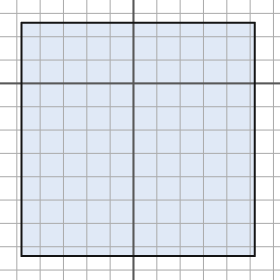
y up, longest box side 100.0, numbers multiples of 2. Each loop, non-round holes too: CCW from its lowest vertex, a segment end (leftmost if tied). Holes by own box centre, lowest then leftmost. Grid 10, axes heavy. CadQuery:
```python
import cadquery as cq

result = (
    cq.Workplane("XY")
    .moveTo(-48.0, -74.0)
    .lineTo(52.0, -74.0)
    .lineTo(52.0, 26.0)
    .lineTo(-48.0, 26.0)
    .close()
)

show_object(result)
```